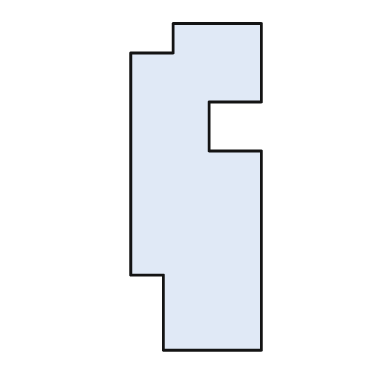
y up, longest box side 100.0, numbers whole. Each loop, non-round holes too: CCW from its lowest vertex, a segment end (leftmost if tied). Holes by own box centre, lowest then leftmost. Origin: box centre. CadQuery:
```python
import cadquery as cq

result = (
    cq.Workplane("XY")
    .moveTo(-10.0, -50.0)
    .lineTo(20.0, -50.0)
    .lineTo(20.0, 11.0)
    .lineTo(4.0, 11.0)
    .lineTo(4.0, 26.0)
    .lineTo(20.0, 26.0)
    .lineTo(20.0, 50.0)
    .lineTo(-7.0, 50.0)
    .lineTo(-7.0, 41.0)
    .lineTo(-20.0, 41.0)
    .lineTo(-20.0, -27.0)
    .lineTo(-10.0, -27.0)
    .close()
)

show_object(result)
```